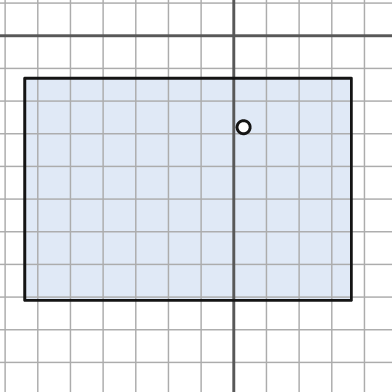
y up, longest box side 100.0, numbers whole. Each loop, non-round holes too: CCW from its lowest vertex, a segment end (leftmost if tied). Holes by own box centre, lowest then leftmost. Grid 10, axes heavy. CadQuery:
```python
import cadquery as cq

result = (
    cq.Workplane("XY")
    .moveTo(-64.0, -81.0)
    .lineTo(36.0, -81.0)
    .lineTo(36.0, -13.0)
    .lineTo(-64.0, -13.0)
    .close()
    .moveTo(3.0, -28.0)
    .circle(2.0)
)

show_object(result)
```